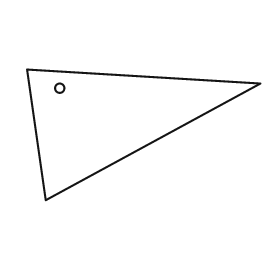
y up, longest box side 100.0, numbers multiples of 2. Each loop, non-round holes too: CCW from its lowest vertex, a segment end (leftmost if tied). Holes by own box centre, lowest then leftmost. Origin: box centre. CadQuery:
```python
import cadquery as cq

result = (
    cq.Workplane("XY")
    .moveTo(-42.0, -28.0)
    .lineTo(50.0, 22.0)
    .lineTo(-50.0, 28.0)
    .close()
    .moveTo(-36.0, 20.0)
    .circle(2.0)
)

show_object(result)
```